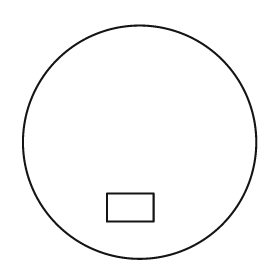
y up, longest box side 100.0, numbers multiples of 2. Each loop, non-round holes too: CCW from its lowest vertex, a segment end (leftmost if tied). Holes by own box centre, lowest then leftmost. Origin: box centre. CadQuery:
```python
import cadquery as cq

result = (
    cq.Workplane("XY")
    .moveTo(0.0, 0.0)
    .circle(50.0)
    .moveTo(-14.0, -34.0)
    .lineTo(6.0, -34.0)
    .lineTo(6.0, -22.0)
    .lineTo(-14.0, -22.0)
    .close()
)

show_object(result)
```